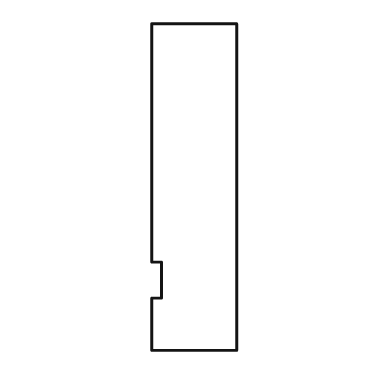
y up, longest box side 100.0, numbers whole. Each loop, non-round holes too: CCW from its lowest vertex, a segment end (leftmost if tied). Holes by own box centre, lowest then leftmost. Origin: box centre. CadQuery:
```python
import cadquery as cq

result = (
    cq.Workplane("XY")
    .moveTo(-13.0, -50.0)
    .lineTo(13.0, -50.0)
    .lineTo(13.0, 50.0)
    .lineTo(-13.0, 50.0)
    .lineTo(-13.0, -23.0)
    .lineTo(-10.0, -23.0)
    .lineTo(-10.0, -34.0)
    .lineTo(-13.0, -34.0)
    .close()
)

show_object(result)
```